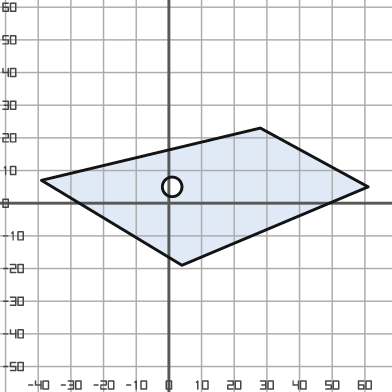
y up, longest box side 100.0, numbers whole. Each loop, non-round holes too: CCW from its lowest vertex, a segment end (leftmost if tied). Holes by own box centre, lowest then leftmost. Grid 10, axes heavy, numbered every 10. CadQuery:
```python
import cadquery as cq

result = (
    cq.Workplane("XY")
    .moveTo(4.0, -19.0)
    .lineTo(61.0, 5.0)
    .lineTo(28.0, 23.0)
    .lineTo(-39.0, 7.0)
    .close()
    .moveTo(1.0, 5.0)
    .circle(3.0)
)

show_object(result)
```